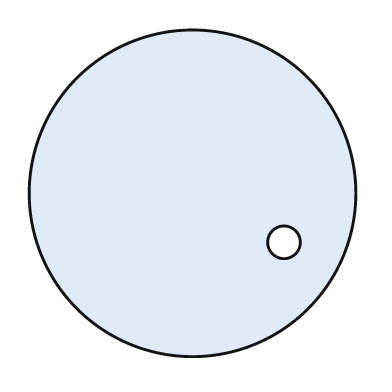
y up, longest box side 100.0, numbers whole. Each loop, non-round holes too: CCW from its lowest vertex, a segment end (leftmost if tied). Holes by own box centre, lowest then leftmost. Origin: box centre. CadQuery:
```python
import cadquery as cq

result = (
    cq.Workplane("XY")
    .moveTo(0.0, 0.0)
    .circle(50.0)
    .moveTo(28.0, -15.0)
    .circle(5.0)
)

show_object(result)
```